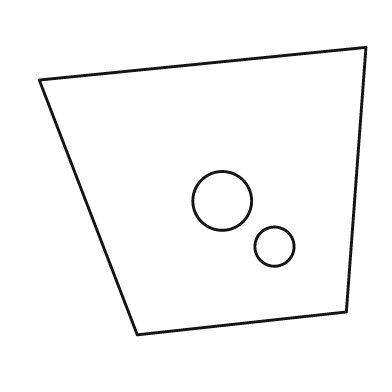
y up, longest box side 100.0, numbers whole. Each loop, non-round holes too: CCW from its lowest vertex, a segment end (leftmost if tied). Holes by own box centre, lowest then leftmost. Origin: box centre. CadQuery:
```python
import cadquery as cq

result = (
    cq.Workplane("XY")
    .moveTo(-20.0, -44.0)
    .lineTo(44.0, -37.0)
    .lineTo(50.0, 44.0)
    .lineTo(-50.0, 34.0)
    .close()
    .moveTo(22.0, -17.0)
    .circle(6.0)
    .moveTo(6.0, -3.0)
    .circle(9.0)
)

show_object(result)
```